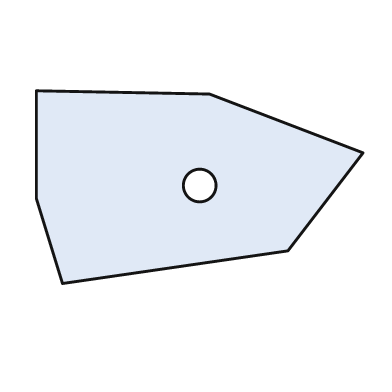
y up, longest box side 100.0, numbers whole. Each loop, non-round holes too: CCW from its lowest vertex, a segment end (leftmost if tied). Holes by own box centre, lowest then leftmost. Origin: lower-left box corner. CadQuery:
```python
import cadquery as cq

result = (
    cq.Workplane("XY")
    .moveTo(8.0, 0.0)
    .lineTo(77.0, 10.0)
    .lineTo(100.0, 40.0)
    .lineTo(53.0, 58.0)
    .lineTo(0.0, 59.0)
    .lineTo(0.0, 26.0)
    .close()
    .moveTo(50.0, 30.0)
    .circle(5.0)
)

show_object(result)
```